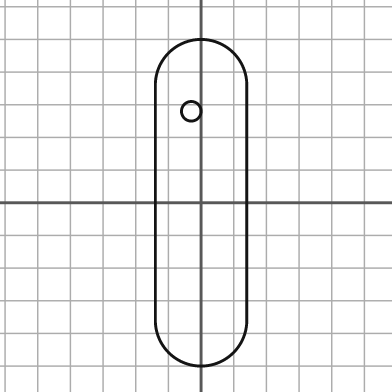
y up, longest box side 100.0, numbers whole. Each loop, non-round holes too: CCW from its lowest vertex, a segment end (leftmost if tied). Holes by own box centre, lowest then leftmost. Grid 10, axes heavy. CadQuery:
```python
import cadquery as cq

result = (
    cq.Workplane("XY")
    .moveTo(-14.0, -36.0)
    .threePointArc((0.0, -50.0), (14.0, -36.0))
    .lineTo(14.0, 36.0)
    .threePointArc((0.0, 50.0), (-14.0, 36.0))
    .close()
    .moveTo(-3.0, 28.0)
    .circle(3.0)
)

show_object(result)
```